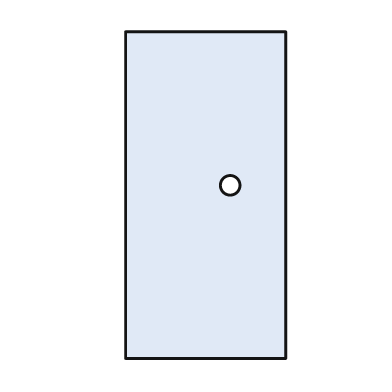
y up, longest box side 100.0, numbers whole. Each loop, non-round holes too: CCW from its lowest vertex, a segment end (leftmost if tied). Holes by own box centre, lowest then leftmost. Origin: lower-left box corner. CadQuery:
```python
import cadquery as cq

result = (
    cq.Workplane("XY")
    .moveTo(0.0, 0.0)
    .lineTo(49.0, 0.0)
    .lineTo(49.0, 100.0)
    .lineTo(0.0, 100.0)
    .close()
    .moveTo(32.0, 53.0)
    .circle(3.0)
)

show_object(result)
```